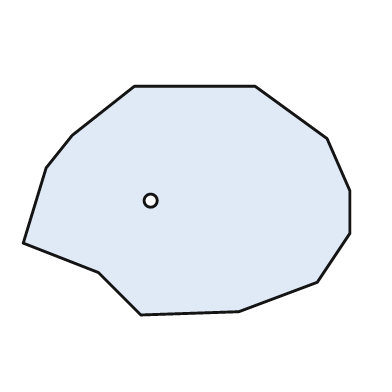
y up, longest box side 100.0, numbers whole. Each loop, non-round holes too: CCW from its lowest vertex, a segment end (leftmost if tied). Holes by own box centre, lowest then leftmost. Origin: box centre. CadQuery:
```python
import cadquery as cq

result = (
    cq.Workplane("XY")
    .moveTo(-14.0, -35.0)
    .lineTo(16.0, -34.0)
    .lineTo(40.0, -25.0)
    .lineTo(50.0, -10.0)
    .lineTo(50.0, 3.0)
    .lineTo(43.0, 19.0)
    .lineTo(21.0, 35.0)
    .lineTo(-16.0, 35.0)
    .lineTo(-35.0, 20.0)
    .lineTo(-43.0, 10.0)
    .lineTo(-50.0, -13.0)
    .lineTo(-27.0, -22.0)
    .close()
    .moveTo(-11.0, 0.0)
    .circle(2.0)
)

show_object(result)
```